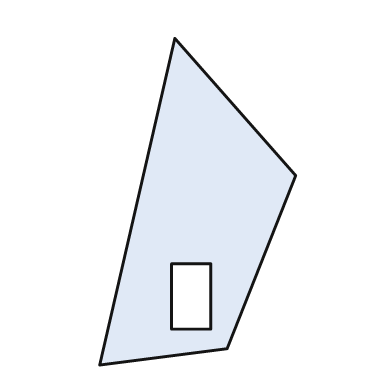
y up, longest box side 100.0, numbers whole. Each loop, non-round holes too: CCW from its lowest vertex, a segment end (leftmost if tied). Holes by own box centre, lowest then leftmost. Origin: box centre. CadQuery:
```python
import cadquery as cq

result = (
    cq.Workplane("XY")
    .moveTo(-30.0, -50.0)
    .lineTo(9.0, -45.0)
    .lineTo(30.0, 8.0)
    .lineTo(-7.0, 50.0)
    .close()
    .moveTo(-8.0, -39.0)
    .lineTo(4.0, -39.0)
    .lineTo(4.0, -19.0)
    .lineTo(-8.0, -19.0)
    .close()
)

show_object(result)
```